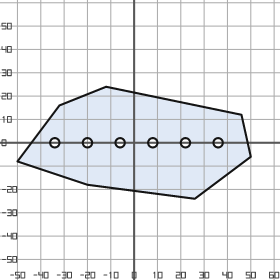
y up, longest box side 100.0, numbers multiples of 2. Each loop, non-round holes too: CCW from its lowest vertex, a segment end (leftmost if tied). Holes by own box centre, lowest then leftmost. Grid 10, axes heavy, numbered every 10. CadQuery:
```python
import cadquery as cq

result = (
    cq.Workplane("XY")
    .moveTo(26.0, -24.0)
    .lineTo(50.0, -6.0)
    .lineTo(46.0, 12.0)
    .lineTo(-12.0, 24.0)
    .lineTo(-32.0, 16.0)
    .lineTo(-50.0, -8.0)
    .lineTo(-20.0, -18.0)
    .close()
    .moveTo(-34.0, 0.0)
    .circle(2.0)
    .moveTo(-20.0, 0.0)
    .circle(2.0)
    .moveTo(-6.0, 0.0)
    .circle(2.0)
    .moveTo(8.0, 0.0)
    .circle(2.0)
    .moveTo(22.0, 0.0)
    .circle(2.0)
    .moveTo(36.0, 0.0)
    .circle(2.0)
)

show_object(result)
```